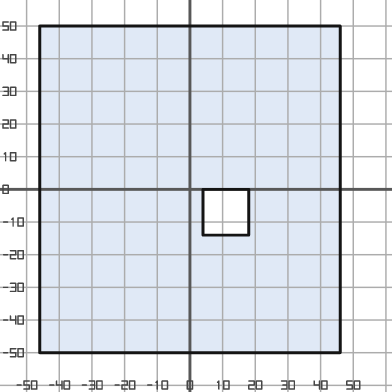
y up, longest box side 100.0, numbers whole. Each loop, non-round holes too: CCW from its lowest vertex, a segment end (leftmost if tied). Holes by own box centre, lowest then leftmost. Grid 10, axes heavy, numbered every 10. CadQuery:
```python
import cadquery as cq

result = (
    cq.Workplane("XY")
    .moveTo(-46.0, -50.0)
    .lineTo(46.0, -50.0)
    .lineTo(46.0, 50.0)
    .lineTo(-46.0, 50.0)
    .close()
    .moveTo(4.0, -14.0)
    .lineTo(18.0, -14.0)
    .lineTo(18.0, 0.0)
    .lineTo(4.0, 0.0)
    .close()
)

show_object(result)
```